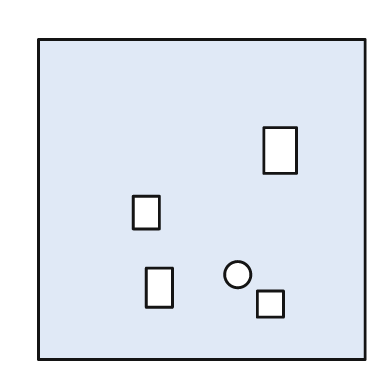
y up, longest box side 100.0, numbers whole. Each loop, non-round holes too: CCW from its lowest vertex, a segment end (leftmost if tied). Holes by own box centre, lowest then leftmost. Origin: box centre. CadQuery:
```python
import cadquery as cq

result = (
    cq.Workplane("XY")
    .moveTo(-50.0, -49.0)
    .lineTo(50.0, -49.0)
    .lineTo(50.0, 49.0)
    .lineTo(-50.0, 49.0)
    .close()
    .moveTo(17.0, -36.0)
    .lineTo(25.0, -36.0)
    .lineTo(25.0, -28.0)
    .lineTo(17.0, -28.0)
    .close()
    .moveTo(-17.0, -33.0)
    .lineTo(-9.0, -33.0)
    .lineTo(-9.0, -21.0)
    .lineTo(-17.0, -21.0)
    .close()
    .moveTo(11.0, -23.0)
    .circle(4.0)
    .moveTo(-21.0, -9.0)
    .lineTo(-13.0, -9.0)
    .lineTo(-13.0, 1.0)
    .lineTo(-21.0, 1.0)
    .close()
    .moveTo(19.0, 8.0)
    .lineTo(29.0, 8.0)
    .lineTo(29.0, 22.0)
    .lineTo(19.0, 22.0)
    .close()
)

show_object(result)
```